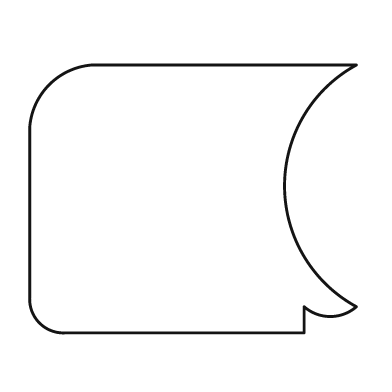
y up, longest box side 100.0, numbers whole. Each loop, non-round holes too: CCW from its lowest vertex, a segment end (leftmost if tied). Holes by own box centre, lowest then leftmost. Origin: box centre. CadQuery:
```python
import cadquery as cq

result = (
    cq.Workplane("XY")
    .moveTo(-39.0, -41.0)
    .lineTo(34.0, -41.0)
    .lineTo(34.0, -33.0)
    .threePointArc((42.0, -36.0), (50.0, -33.0))
    .threePointArc((28.0, 4.0), (50.0, 41.0))
    .lineTo(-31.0, 41.0)
    .threePointArc((-44.0, 35.0), (-50.0, 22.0))
    .lineTo(-50.0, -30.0)
    .threePointArc((-47.0, -38.0), (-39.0, -41.0))
    .close()
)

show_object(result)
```